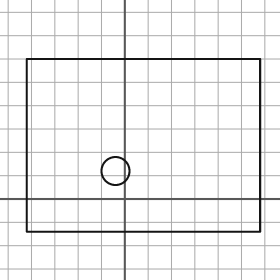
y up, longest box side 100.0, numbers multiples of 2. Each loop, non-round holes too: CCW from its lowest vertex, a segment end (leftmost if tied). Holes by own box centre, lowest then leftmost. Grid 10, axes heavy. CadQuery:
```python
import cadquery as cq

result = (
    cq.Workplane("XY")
    .moveTo(-42.0, -14.0)
    .lineTo(58.0, -14.0)
    .lineTo(58.0, 60.0)
    .lineTo(-42.0, 60.0)
    .close()
    .moveTo(-4.0, 12.0)
    .circle(6.0)
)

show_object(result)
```